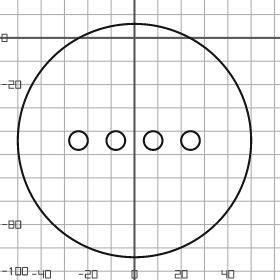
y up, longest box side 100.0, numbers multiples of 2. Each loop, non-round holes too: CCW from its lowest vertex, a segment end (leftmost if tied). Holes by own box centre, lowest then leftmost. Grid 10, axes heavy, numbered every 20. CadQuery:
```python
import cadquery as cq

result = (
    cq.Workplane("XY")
    .moveTo(0.0, -44.0)
    .circle(50.0)
    .moveTo(-24.0, -44.0)
    .circle(4.0)
    .moveTo(-8.0, -44.0)
    .circle(4.0)
    .moveTo(8.0, -44.0)
    .circle(4.0)
    .moveTo(24.0, -44.0)
    .circle(4.0)
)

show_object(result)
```